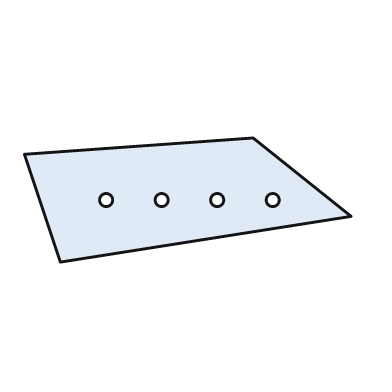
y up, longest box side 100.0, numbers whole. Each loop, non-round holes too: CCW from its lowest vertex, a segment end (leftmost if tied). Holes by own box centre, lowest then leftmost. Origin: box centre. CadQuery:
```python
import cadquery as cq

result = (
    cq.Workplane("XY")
    .moveTo(-39.0, -19.0)
    .lineTo(50.0, -5.0)
    .lineTo(20.0, 19.0)
    .lineTo(-50.0, 14.0)
    .close()
    .moveTo(-25.0, 0.0)
    .circle(2.0)
    .moveTo(-8.0, 0.0)
    .circle(2.0)
    .moveTo(9.0, 0.0)
    .circle(2.0)
    .moveTo(26.0, 0.0)
    .circle(2.0)
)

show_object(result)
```